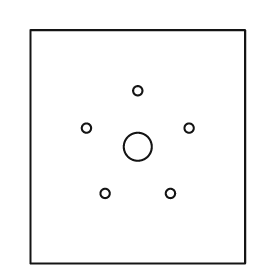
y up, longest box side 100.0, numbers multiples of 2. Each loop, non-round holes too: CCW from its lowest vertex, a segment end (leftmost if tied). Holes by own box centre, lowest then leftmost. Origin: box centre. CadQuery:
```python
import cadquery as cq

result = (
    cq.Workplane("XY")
    .moveTo(-46.0, -50.0)
    .lineTo(46.0, -50.0)
    .lineTo(46.0, 50.0)
    .lineTo(-46.0, 50.0)
    .close()
    .moveTo(-14.0, -20.0)
    .circle(2.0)
    .moveTo(14.0, -20.0)
    .circle(2.0)
    .moveTo(0.0, 0.0)
    .circle(6.0)
    .moveTo(-22.0, 8.0)
    .circle(2.0)
    .moveTo(22.0, 8.0)
    .circle(2.0)
    .moveTo(0.0, 24.0)
    .circle(2.0)
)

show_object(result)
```